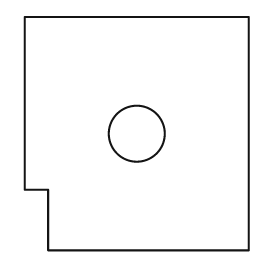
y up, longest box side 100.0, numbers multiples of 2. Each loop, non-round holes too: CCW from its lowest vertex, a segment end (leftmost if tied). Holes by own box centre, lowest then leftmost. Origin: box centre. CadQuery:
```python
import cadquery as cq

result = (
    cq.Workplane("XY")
    .moveTo(-38.0, -50.0)
    .lineTo(48.0, -50.0)
    .lineTo(48.0, 50.0)
    .lineTo(-48.0, 50.0)
    .lineTo(-48.0, -24.0)
    .lineTo(-38.0, -24.0)
    .close()
    .moveTo(0.0, 0.0)
    .circle(12.0)
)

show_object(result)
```